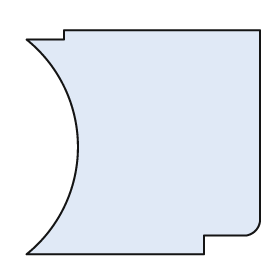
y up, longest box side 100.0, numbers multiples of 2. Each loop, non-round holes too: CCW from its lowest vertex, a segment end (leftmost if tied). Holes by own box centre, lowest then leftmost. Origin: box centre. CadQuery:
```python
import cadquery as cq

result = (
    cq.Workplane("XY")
    .moveTo(-50.0, -48.0)
    .lineTo(26.0, -48.0)
    .lineTo(26.0, -40.0)
    .lineTo(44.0, -40.0)
    .threePointArc((48.0, -38.0), (50.0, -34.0))
    .lineTo(50.0, 48.0)
    .lineTo(-34.0, 48.0)
    .lineTo(-34.0, 44.0)
    .lineTo(-50.0, 44.0)
    .threePointArc((-28.0, -2.0), (-50.0, -48.0))
    .close()
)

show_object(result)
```